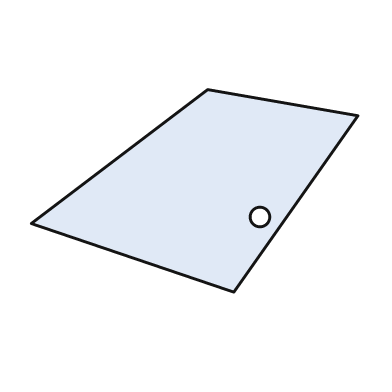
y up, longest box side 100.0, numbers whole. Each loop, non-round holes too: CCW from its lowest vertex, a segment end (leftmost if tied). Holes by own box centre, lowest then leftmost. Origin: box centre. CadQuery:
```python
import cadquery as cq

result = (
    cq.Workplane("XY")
    .moveTo(12.0, -31.0)
    .lineTo(50.0, 23.0)
    .lineTo(4.0, 31.0)
    .lineTo(-50.0, -10.0)
    .close()
    .moveTo(20.0, -8.0)
    .circle(3.0)
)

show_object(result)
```